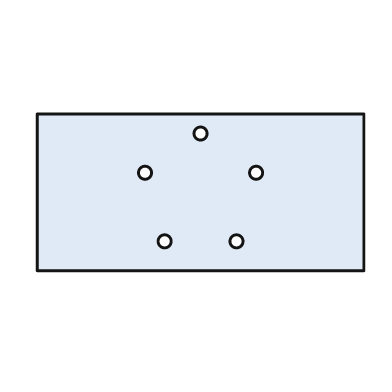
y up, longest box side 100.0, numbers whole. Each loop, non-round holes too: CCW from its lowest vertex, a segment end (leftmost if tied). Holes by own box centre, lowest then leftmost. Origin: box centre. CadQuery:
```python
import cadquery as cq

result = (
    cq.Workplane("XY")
    .moveTo(-50.0, -24.0)
    .lineTo(50.0, -24.0)
    .lineTo(50.0, 24.0)
    .lineTo(-50.0, 24.0)
    .close()
    .moveTo(-11.0, -15.0)
    .circle(2.0)
    .moveTo(11.0, -15.0)
    .circle(2.0)
    .moveTo(-17.0, 6.0)
    .circle(2.0)
    .moveTo(17.0, 6.0)
    .circle(2.0)
    .moveTo(0.0, 18.0)
    .circle(2.0)
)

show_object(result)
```